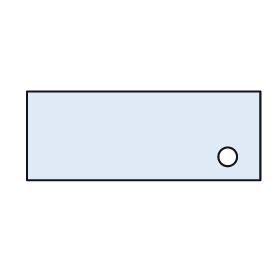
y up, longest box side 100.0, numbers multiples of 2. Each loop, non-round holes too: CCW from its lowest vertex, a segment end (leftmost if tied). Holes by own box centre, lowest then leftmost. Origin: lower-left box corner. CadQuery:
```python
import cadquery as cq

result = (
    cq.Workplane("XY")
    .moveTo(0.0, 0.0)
    .lineTo(100.0, 0.0)
    .lineTo(100.0, 38.0)
    .lineTo(0.0, 38.0)
    .close()
    .moveTo(86.0, 10.0)
    .circle(4.0)
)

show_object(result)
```